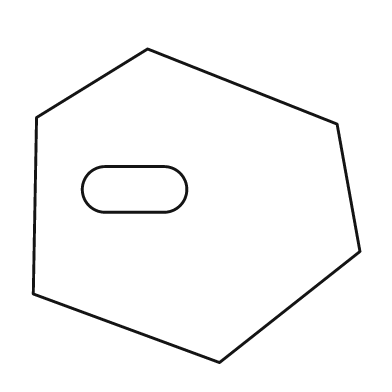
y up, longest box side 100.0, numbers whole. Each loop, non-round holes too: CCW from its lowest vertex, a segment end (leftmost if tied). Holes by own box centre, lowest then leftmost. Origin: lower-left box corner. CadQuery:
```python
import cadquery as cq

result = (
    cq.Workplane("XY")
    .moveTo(57.0, 0.0)
    .lineTo(100.0, 34.0)
    .lineTo(93.0, 73.0)
    .lineTo(35.0, 96.0)
    .lineTo(1.0, 75.0)
    .lineTo(0.0, 21.0)
    .close()
    .moveTo(22.0, 46.0)
    .lineTo(40.0, 46.0)
    .threePointArc((47.0, 53.0), (40.0, 60.0))
    .lineTo(22.0, 60.0)
    .threePointArc((15.0, 53.0), (22.0, 46.0))
    .close()
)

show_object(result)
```